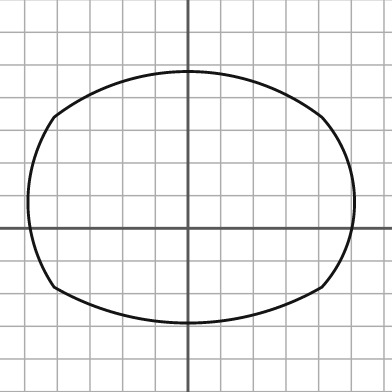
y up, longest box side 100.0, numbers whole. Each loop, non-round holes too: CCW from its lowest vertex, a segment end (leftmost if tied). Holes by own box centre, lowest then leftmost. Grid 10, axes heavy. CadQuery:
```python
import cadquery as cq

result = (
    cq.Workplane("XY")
    .moveTo(-41.0, -18.0)
    .threePointArc((0.0, -29.0), (41.0, -18.0))
    .threePointArc((51.0, 8.0), (41.0, 34.0))
    .threePointArc((0.0, 48.0), (-41.0, 34.0))
    .threePointArc((-49.0, 8.0), (-41.0, -18.0))
    .close()
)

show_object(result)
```